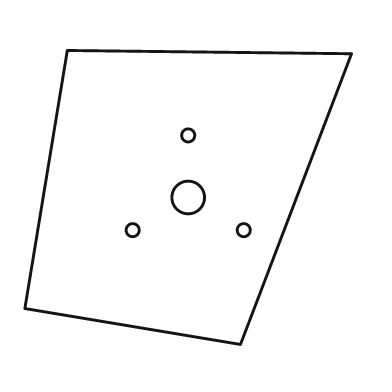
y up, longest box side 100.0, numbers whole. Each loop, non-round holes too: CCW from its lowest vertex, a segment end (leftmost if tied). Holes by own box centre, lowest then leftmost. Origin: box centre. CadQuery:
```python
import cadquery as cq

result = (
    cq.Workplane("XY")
    .moveTo(16.0, -45.0)
    .lineTo(50.0, 44.0)
    .lineTo(-37.0, 45.0)
    .lineTo(-50.0, -34.0)
    .close()
    .moveTo(-17.0, -10.0)
    .circle(2.0)
    .moveTo(17.0, -10.0)
    .circle(2.0)
    .moveTo(0.0, 0.0)
    .circle(5.0)
    .moveTo(0.0, 19.0)
    .circle(2.0)
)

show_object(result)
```